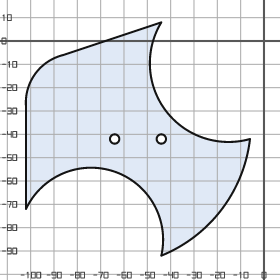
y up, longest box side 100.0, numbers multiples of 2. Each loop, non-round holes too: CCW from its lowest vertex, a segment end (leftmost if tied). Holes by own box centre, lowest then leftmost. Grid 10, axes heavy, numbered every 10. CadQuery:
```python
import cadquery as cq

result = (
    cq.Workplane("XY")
    .moveTo(-44.0, -92.0)
    .threePointArc((-18.0, -72.0), (-6.0, -42.0))
    .threePointArc((-42.0, -30.0), (-44.0, 8.0))
    .lineTo(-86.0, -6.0)
    .threePointArc((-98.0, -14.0), (-102.0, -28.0))
    .lineTo(-102.0, -72.0)
    .threePointArc((-64.0, -56.0), (-44.0, -92.0))
    .close()
    .moveTo(-64.0, -42.0)
    .circle(2.0)
    .moveTo(-44.0, -42.0)
    .circle(2.0)
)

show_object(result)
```